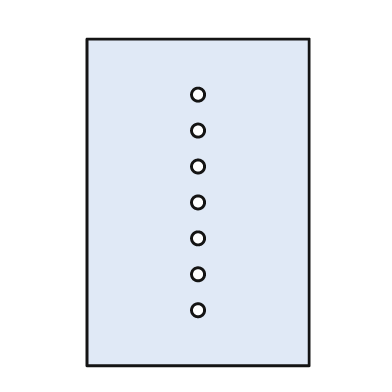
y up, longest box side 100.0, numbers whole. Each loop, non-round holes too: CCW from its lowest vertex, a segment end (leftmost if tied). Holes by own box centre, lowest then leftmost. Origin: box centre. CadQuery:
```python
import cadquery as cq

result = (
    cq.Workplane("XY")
    .moveTo(-34.0, -50.0)
    .lineTo(34.0, -50.0)
    .lineTo(34.0, 50.0)
    .lineTo(-34.0, 50.0)
    .close()
    .moveTo(0.0, -33.0)
    .circle(2.0)
    .moveTo(0.0, -22.0)
    .circle(2.0)
    .moveTo(0.0, -11.0)
    .circle(2.0)
    .moveTo(0.0, 0.0)
    .circle(2.0)
    .moveTo(0.0, 11.0)
    .circle(2.0)
    .moveTo(0.0, 22.0)
    .circle(2.0)
    .moveTo(0.0, 33.0)
    .circle(2.0)
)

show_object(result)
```